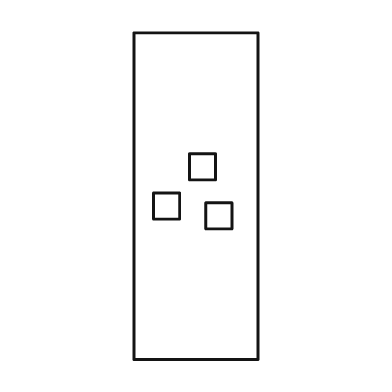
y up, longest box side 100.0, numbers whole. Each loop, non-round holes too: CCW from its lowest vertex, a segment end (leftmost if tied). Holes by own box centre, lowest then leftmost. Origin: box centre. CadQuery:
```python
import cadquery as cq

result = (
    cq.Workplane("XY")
    .moveTo(-19.0, -50.0)
    .lineTo(19.0, -50.0)
    .lineTo(19.0, 50.0)
    .lineTo(-19.0, 50.0)
    .close()
    .moveTo(3.0, -10.0)
    .lineTo(11.0, -10.0)
    .lineTo(11.0, -2.0)
    .lineTo(3.0, -2.0)
    .close()
    .moveTo(-13.0, -7.0)
    .lineTo(-5.0, -7.0)
    .lineTo(-5.0, 1.0)
    .lineTo(-13.0, 1.0)
    .close()
    .moveTo(-2.0, 5.0)
    .lineTo(6.0, 5.0)
    .lineTo(6.0, 13.0)
    .lineTo(-2.0, 13.0)
    .close()
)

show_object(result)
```